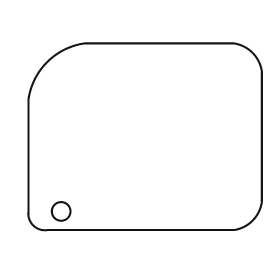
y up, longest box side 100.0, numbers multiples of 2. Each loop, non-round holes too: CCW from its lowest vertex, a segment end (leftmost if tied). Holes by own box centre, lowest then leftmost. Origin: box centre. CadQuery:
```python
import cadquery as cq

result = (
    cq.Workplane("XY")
    .moveTo(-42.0, -40.0)
    .lineTo(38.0, -40.0)
    .threePointArc((46.0, -36.0), (50.0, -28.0))
    .lineTo(50.0, 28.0)
    .threePointArc((46.0, 36.0), (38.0, 40.0))
    .lineTo(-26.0, 40.0)
    .threePointArc((-42.0, 32.0), (-50.0, 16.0))
    .lineTo(-50.0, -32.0)
    .threePointArc((-48.0, -38.0), (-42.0, -40.0))
    .close()
    .moveTo(-36.0, -32.0)
    .circle(4.0)
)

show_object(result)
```